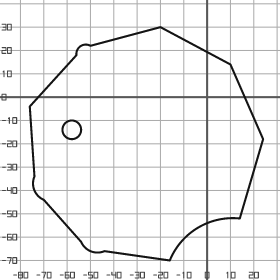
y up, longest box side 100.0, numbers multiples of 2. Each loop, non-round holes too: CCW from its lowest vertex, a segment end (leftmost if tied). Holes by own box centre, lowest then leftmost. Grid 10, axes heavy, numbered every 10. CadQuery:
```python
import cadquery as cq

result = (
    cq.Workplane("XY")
    .moveTo(-16.0, -70.0)
    .threePointArc((-4.0, -56.0), (14.0, -52.0))
    .lineTo(24.0, -18.0)
    .lineTo(10.0, 14.0)
    .lineTo(-20.0, 30.0)
    .lineTo(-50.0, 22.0)
    .threePointArc((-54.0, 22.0), (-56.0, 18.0))
    .lineTo(-76.0, -4.0)
    .lineTo(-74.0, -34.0)
    .threePointArc((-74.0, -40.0), (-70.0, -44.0))
    .lineTo(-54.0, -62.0)
    .threePointArc((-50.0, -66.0), (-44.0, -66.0))
    .close()
    .moveTo(-58.0, -14.0)
    .circle(4.0)
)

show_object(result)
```